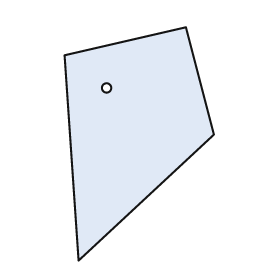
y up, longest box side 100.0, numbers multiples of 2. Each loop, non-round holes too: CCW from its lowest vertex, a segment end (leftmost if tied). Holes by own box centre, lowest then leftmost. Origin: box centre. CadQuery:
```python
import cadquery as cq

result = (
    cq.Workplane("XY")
    .moveTo(-26.0, -50.0)
    .lineTo(32.0, 4.0)
    .lineTo(20.0, 50.0)
    .lineTo(-32.0, 38.0)
    .close()
    .moveTo(-14.0, 24.0)
    .circle(2.0)
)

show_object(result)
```